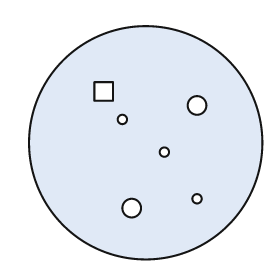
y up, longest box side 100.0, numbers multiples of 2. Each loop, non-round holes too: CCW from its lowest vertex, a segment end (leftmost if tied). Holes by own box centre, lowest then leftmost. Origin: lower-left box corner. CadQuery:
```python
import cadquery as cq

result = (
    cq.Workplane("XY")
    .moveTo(50.0, 50.0)
    .circle(50.0)
    .moveTo(44.0, 22.0)
    .circle(4.0)
    .moveTo(72.0, 26.0)
    .circle(2.0)
    .moveTo(58.0, 46.0)
    .circle(2.0)
    .moveTo(40.0, 60.0)
    .circle(2.0)
    .moveTo(72.0, 66.0)
    .circle(4.0)
    .moveTo(28.0, 68.0)
    .lineTo(36.0, 68.0)
    .lineTo(36.0, 76.0)
    .lineTo(28.0, 76.0)
    .close()
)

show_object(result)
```